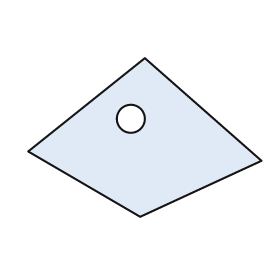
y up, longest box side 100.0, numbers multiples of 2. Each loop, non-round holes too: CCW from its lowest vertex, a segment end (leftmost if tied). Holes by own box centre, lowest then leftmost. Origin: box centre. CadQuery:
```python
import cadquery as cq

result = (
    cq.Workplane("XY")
    .moveTo(-2.0, -34.0)
    .lineTo(50.0, -10.0)
    .lineTo(0.0, 34.0)
    .lineTo(-50.0, -6.0)
    .close()
    .moveTo(-6.0, 8.0)
    .circle(6.0)
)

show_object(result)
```